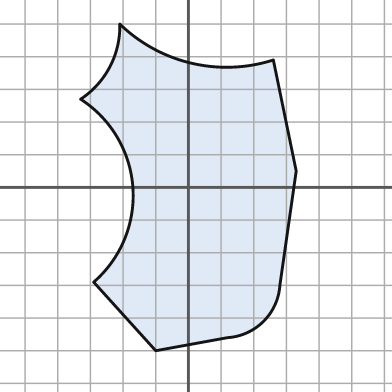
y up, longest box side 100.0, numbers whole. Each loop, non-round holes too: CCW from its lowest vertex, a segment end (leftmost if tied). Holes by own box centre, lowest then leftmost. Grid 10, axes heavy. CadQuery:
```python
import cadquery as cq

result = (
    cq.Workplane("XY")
    .moveTo(-10.0, -50.0)
    .lineTo(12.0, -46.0)
    .threePointArc((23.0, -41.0), (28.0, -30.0))
    .lineTo(33.0, 5.0)
    .lineTo(26.0, 39.0)
    .threePointArc((1.0, 38.0), (-21.0, 50.0))
    .threePointArc((-24.0, 37.0), (-33.0, 27.0))
    .threePointArc((-17.0, 0.0), (-29.0, -29.0))
    .close()
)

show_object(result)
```